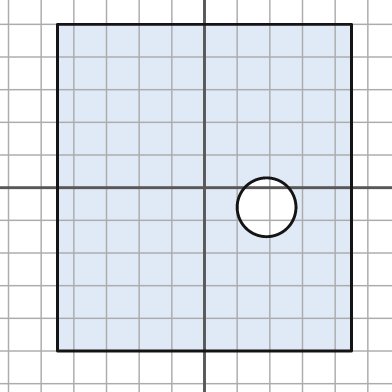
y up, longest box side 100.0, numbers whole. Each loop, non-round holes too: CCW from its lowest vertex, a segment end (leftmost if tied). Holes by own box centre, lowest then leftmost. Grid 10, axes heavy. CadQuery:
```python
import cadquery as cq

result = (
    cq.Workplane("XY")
    .moveTo(-45.0, -50.0)
    .lineTo(45.0, -50.0)
    .lineTo(45.0, 50.0)
    .lineTo(-45.0, 50.0)
    .close()
    .moveTo(19.0, -6.0)
    .circle(9.0)
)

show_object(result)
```